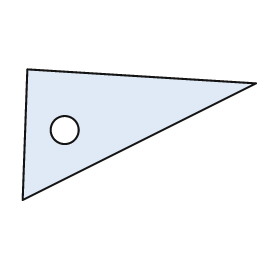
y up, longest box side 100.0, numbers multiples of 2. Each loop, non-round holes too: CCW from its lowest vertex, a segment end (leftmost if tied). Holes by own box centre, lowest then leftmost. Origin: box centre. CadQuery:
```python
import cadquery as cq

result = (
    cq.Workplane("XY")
    .moveTo(-50.0, -28.0)
    .lineTo(50.0, 22.0)
    .lineTo(-48.0, 28.0)
    .close()
    .moveTo(-32.0, 2.0)
    .circle(6.0)
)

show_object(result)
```